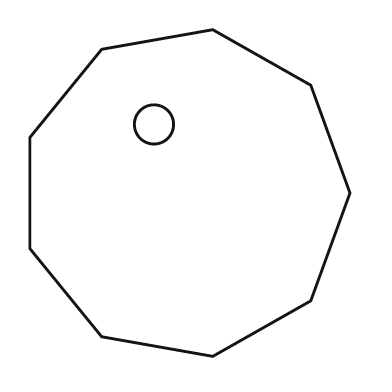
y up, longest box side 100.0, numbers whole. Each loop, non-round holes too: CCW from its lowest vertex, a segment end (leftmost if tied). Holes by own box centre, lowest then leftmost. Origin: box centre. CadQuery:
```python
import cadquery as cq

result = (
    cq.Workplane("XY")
    .moveTo(7.0, -50.0)
    .lineTo(37.0, -33.0)
    .lineTo(49.0, 0.0)
    .lineTo(37.0, 33.0)
    .lineTo(7.0, 50.0)
    .lineTo(-27.0, 44.0)
    .lineTo(-49.0, 17.0)
    .lineTo(-49.0, -17.0)
    .lineTo(-27.0, -44.0)
    .close()
    .moveTo(-11.0, 21.0)
    .circle(6.0)
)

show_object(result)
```